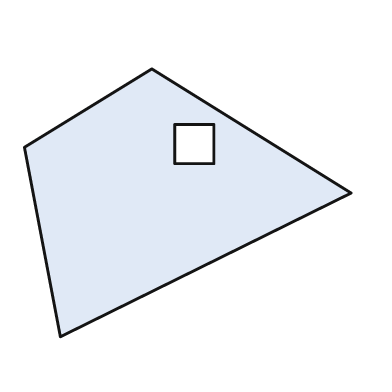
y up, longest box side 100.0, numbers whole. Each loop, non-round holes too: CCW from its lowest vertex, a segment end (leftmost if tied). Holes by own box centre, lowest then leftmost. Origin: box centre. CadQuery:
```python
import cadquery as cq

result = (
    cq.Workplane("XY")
    .moveTo(-39.0, -41.0)
    .lineTo(50.0, 3.0)
    .lineTo(-11.0, 41.0)
    .lineTo(-50.0, 17.0)
    .close()
    .moveTo(-4.0, 12.0)
    .lineTo(8.0, 12.0)
    .lineTo(8.0, 24.0)
    .lineTo(-4.0, 24.0)
    .close()
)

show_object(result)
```